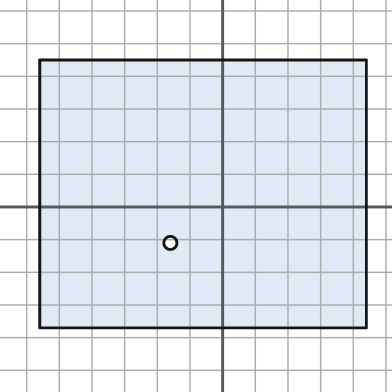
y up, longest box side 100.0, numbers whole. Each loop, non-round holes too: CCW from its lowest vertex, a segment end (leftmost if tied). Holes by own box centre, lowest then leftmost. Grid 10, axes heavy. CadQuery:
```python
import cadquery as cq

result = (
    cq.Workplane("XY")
    .moveTo(-56.0, -37.0)
    .lineTo(44.0, -37.0)
    .lineTo(44.0, 45.0)
    .lineTo(-56.0, 45.0)
    .close()
    .moveTo(-16.0, -11.0)
    .circle(2.0)
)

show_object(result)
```